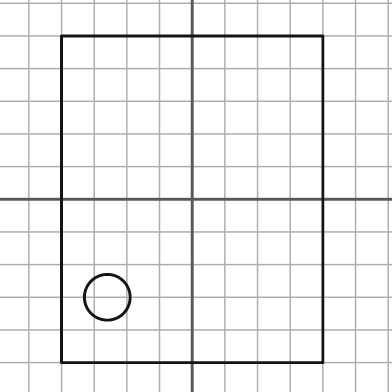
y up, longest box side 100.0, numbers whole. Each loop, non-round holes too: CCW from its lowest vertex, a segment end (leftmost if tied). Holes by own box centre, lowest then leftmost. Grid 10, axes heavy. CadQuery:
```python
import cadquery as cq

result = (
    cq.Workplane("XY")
    .moveTo(-40.0, -50.0)
    .lineTo(40.0, -50.0)
    .lineTo(40.0, 50.0)
    .lineTo(-40.0, 50.0)
    .close()
    .moveTo(-26.0, -30.0)
    .circle(7.0)
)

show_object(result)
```